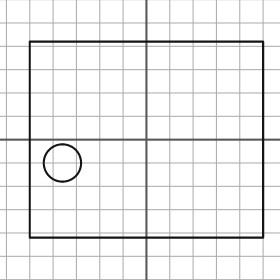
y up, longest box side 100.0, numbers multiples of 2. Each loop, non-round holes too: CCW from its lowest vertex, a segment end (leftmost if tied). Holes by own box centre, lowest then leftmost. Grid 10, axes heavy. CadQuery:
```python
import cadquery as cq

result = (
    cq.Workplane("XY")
    .moveTo(-50.0, -42.0)
    .lineTo(50.0, -42.0)
    .lineTo(50.0, 42.0)
    .lineTo(-50.0, 42.0)
    .close()
    .moveTo(-36.0, -10.0)
    .circle(8.0)
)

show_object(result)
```